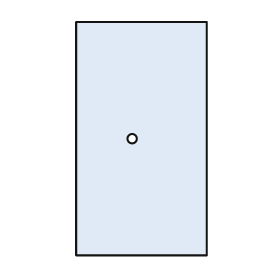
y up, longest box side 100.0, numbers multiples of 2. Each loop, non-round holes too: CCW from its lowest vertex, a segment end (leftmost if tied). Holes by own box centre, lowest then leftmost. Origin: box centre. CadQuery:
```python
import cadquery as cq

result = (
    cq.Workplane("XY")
    .moveTo(-28.0, -50.0)
    .lineTo(28.0, -50.0)
    .lineTo(28.0, 50.0)
    .lineTo(-28.0, 50.0)
    .close()
    .moveTo(-4.0, 0.0)
    .circle(2.0)
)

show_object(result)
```